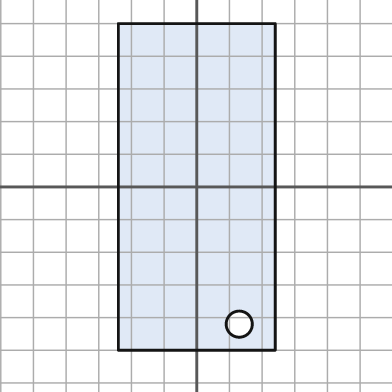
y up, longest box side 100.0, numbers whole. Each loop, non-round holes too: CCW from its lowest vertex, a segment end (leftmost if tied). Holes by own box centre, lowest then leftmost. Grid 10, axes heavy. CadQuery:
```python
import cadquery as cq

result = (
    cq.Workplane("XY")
    .moveTo(-24.0, -50.0)
    .lineTo(24.0, -50.0)
    .lineTo(24.0, 50.0)
    .lineTo(-24.0, 50.0)
    .close()
    .moveTo(13.0, -42.0)
    .circle(4.0)
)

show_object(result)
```